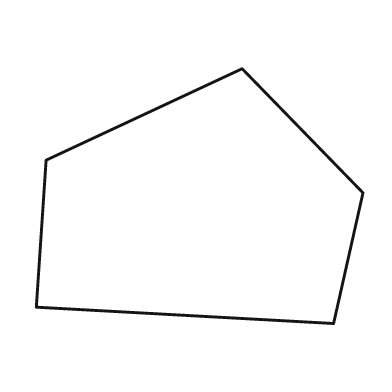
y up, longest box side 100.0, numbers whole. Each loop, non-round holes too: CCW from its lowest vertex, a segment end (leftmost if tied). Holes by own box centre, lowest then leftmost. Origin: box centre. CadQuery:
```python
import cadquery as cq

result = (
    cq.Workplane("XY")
    .moveTo(41.0, -39.0)
    .lineTo(50.0, 1.0)
    .lineTo(13.0, 39.0)
    .lineTo(-47.0, 11.0)
    .lineTo(-50.0, -34.0)
    .close()
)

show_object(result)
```